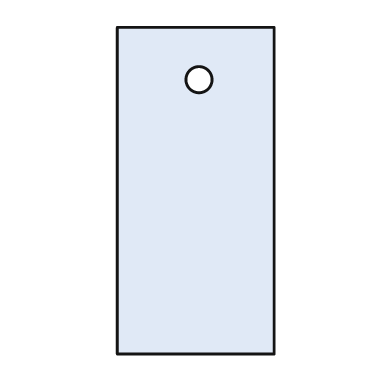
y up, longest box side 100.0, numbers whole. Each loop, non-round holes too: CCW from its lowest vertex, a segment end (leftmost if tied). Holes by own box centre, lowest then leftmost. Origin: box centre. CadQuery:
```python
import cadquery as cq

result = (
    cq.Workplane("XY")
    .moveTo(-24.0, -50.0)
    .lineTo(24.0, -50.0)
    .lineTo(24.0, 50.0)
    .lineTo(-24.0, 50.0)
    .close()
    .moveTo(1.0, 34.0)
    .circle(4.0)
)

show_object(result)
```